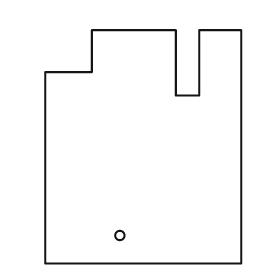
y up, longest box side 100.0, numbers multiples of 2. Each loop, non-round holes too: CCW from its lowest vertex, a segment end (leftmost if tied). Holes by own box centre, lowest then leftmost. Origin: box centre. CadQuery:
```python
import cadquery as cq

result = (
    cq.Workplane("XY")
    .moveTo(-42.0, -50.0)
    .lineTo(42.0, -50.0)
    .lineTo(42.0, 50.0)
    .lineTo(24.0, 50.0)
    .lineTo(24.0, 22.0)
    .lineTo(14.0, 22.0)
    .lineTo(14.0, 50.0)
    .lineTo(-22.0, 50.0)
    .lineTo(-22.0, 32.0)
    .lineTo(-42.0, 32.0)
    .close()
    .moveTo(-10.0, -38.0)
    .circle(2.0)
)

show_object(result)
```